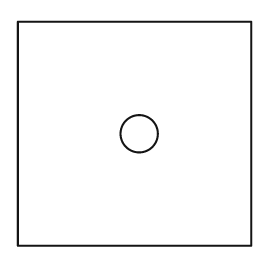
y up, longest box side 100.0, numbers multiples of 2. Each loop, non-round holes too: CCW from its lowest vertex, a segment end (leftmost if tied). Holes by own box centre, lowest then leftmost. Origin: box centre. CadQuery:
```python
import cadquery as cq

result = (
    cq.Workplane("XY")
    .moveTo(-50.0, -48.0)
    .lineTo(50.0, -48.0)
    .lineTo(50.0, 48.0)
    .lineTo(-50.0, 48.0)
    .close()
    .moveTo(2.0, 0.0)
    .circle(8.0)
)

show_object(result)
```